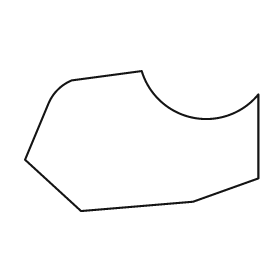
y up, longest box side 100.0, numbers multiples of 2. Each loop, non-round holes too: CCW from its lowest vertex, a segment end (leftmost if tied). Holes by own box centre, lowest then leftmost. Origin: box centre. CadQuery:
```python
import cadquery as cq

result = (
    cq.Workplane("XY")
    .moveTo(-26.0, -30.0)
    .lineTo(22.0, -26.0)
    .lineTo(50.0, -16.0)
    .lineTo(50.0, 20.0)
    .threePointArc((22.0, 10.0), (0.0, 30.0))
    .lineTo(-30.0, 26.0)
    .threePointArc((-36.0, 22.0), (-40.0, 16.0))
    .lineTo(-50.0, -8.0)
    .close()
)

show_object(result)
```